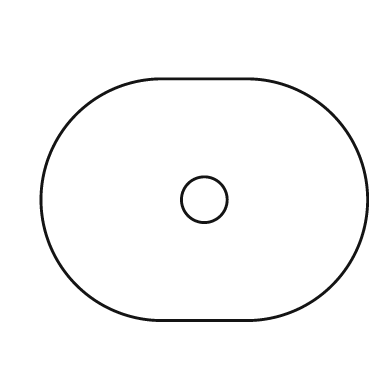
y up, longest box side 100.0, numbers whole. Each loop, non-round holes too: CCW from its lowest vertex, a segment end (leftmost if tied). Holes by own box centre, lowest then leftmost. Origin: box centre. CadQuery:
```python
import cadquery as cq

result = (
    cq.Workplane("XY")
    .moveTo(-13.0, -37.0)
    .lineTo(13.0, -37.0)
    .threePointArc((50.0, 0.0), (13.0, 37.0))
    .lineTo(-13.0, 37.0)
    .threePointArc((-50.0, 0.0), (-13.0, -37.0))
    .close()
    .moveTo(0.0, 0.0)
    .circle(7.0)
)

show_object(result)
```